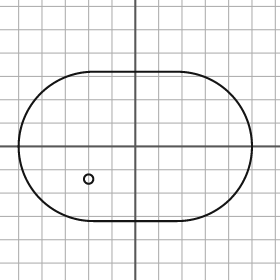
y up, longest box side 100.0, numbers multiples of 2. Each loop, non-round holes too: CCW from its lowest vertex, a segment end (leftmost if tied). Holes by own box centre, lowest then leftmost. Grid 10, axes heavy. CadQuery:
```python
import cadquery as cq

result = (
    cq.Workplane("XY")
    .moveTo(-18.0, -32.0)
    .lineTo(18.0, -32.0)
    .threePointArc((50.0, 0.0), (18.0, 32.0))
    .lineTo(-18.0, 32.0)
    .threePointArc((-50.0, 0.0), (-18.0, -32.0))
    .close()
    .moveTo(-20.0, -14.0)
    .circle(2.0)
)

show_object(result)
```